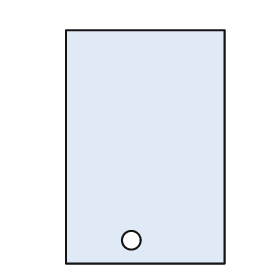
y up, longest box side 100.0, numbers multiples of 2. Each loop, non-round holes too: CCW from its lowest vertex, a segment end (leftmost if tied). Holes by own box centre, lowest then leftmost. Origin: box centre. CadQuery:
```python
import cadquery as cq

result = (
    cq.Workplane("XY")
    .moveTo(-34.0, -50.0)
    .lineTo(34.0, -50.0)
    .lineTo(34.0, 50.0)
    .lineTo(-34.0, 50.0)
    .close()
    .moveTo(-6.0, -40.0)
    .circle(4.0)
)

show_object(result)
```